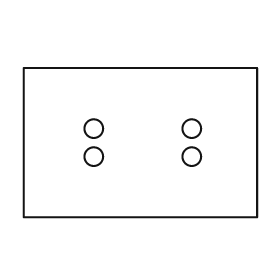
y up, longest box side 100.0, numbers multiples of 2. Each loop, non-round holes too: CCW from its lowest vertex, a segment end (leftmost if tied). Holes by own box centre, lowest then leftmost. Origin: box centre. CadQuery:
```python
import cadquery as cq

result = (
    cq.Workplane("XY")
    .moveTo(-50.0, -32.0)
    .lineTo(50.0, -32.0)
    .lineTo(50.0, 32.0)
    .lineTo(-50.0, 32.0)
    .close()
    .moveTo(-20.0, -6.0)
    .circle(4.0)
    .moveTo(22.0, -6.0)
    .circle(4.0)
    .moveTo(-20.0, 6.0)
    .circle(4.0)
    .moveTo(22.0, 6.0)
    .circle(4.0)
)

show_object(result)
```